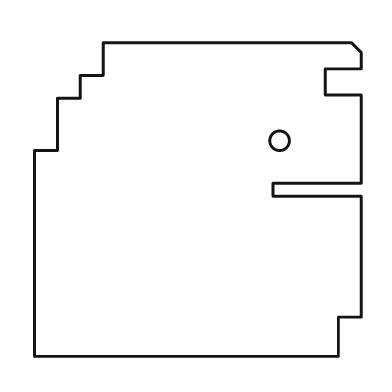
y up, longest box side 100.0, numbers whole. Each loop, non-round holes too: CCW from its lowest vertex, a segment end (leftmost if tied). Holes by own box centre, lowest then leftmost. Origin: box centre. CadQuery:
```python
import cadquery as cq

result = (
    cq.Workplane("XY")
    .moveTo(-50.0, -48.0)
    .lineTo(43.0, -48.0)
    .lineTo(43.0, -36.0)
    .lineTo(50.0, -36.0)
    .lineTo(50.0, 1.0)
    .lineTo(23.0, 1.0)
    .lineTo(23.0, 5.0)
    .lineTo(50.0, 5.0)
    .lineTo(50.0, 32.0)
    .lineTo(39.0, 32.0)
    .lineTo(39.0, 40.0)
    .lineTo(50.0, 40.0)
    .lineTo(50.0, 45.0)
    .lineTo(47.0, 48.0)
    .lineTo(-29.0, 48.0)
    .lineTo(-29.0, 38.0)
    .lineTo(-36.0, 38.0)
    .lineTo(-36.0, 31.0)
    .lineTo(-43.0, 31.0)
    .lineTo(-43.0, 15.0)
    .lineTo(-50.0, 15.0)
    .close()
    .moveTo(25.0, 18.0)
    .circle(3.0)
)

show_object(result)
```